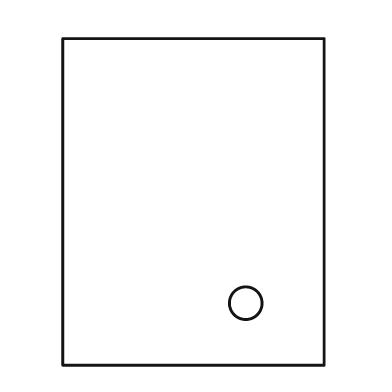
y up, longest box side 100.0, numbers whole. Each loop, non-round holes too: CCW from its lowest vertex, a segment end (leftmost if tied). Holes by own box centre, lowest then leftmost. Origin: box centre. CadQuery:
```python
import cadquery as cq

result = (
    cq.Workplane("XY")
    .moveTo(-40.0, -50.0)
    .lineTo(40.0, -50.0)
    .lineTo(40.0, 50.0)
    .lineTo(-40.0, 50.0)
    .close()
    .moveTo(16.0, -31.0)
    .circle(5.0)
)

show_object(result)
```